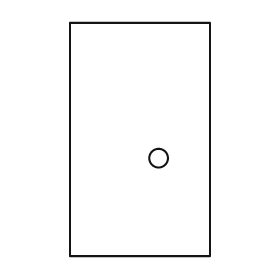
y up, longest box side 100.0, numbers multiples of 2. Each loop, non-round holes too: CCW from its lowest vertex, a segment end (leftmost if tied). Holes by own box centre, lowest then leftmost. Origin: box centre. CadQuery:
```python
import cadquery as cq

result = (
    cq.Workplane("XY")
    .moveTo(-30.0, -50.0)
    .lineTo(30.0, -50.0)
    .lineTo(30.0, 50.0)
    .lineTo(-30.0, 50.0)
    .close()
    .moveTo(8.0, -8.0)
    .circle(4.0)
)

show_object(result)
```